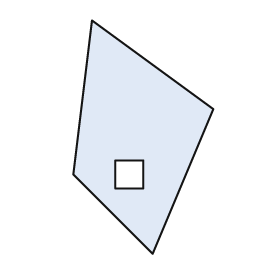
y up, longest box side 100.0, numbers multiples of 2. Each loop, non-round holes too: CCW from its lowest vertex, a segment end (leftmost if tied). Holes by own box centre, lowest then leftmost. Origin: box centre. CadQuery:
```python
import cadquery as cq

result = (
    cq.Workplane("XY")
    .moveTo(4.0, -50.0)
    .lineTo(30.0, 12.0)
    .lineTo(-22.0, 50.0)
    .lineTo(-30.0, -16.0)
    .close()
    .moveTo(-12.0, -22.0)
    .lineTo(0.0, -22.0)
    .lineTo(0.0, -10.0)
    .lineTo(-12.0, -10.0)
    .close()
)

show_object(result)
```